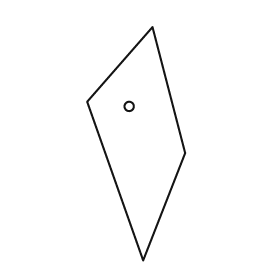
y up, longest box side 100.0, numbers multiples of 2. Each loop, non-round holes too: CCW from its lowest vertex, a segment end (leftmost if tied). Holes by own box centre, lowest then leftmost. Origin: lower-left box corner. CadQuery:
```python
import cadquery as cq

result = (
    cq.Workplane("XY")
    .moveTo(24.0, 0.0)
    .lineTo(42.0, 46.0)
    .lineTo(28.0, 100.0)
    .lineTo(0.0, 68.0)
    .close()
    .moveTo(18.0, 66.0)
    .circle(2.0)
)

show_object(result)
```